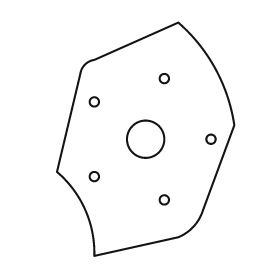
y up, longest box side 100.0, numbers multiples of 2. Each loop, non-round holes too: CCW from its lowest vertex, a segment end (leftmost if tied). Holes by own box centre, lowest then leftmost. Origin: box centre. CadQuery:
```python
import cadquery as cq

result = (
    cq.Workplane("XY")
    .moveTo(-22.0, -50.0)
    .lineTo(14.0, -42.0)
    .threePointArc((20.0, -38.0), (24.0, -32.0))
    .lineTo(38.0, 6.0)
    .threePointArc((30.0, 30.0), (14.0, 50.0))
    .lineTo(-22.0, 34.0)
    .threePointArc((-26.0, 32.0), (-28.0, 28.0))
    .lineTo(-38.0, -14.0)
    .threePointArc((-26.0, -30.0), (-22.0, -50.0))
    .close()
    .moveTo(8.0, -26.0)
    .circle(2.0)
    .moveTo(-22.0, -16.0)
    .circle(2.0)
    .moveTo(0.0, 0.0)
    .circle(8.0)
    .moveTo(28.0, 0.0)
    .circle(2.0)
    .moveTo(-22.0, 16.0)
    .circle(2.0)
    .moveTo(8.0, 26.0)
    .circle(2.0)
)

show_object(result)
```